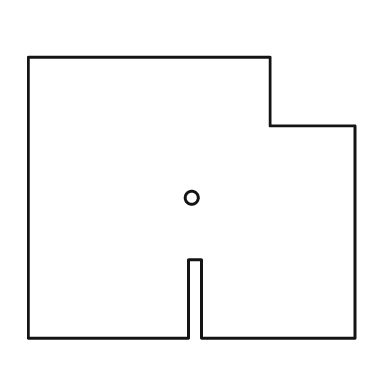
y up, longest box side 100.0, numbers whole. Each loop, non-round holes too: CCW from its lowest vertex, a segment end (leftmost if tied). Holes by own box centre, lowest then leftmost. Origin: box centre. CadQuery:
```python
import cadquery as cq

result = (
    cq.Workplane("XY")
    .moveTo(-50.0, -43.0)
    .lineTo(-1.0, -43.0)
    .lineTo(-1.0, -19.0)
    .lineTo(3.0, -19.0)
    .lineTo(3.0, -43.0)
    .lineTo(50.0, -43.0)
    .lineTo(50.0, 22.0)
    .lineTo(24.0, 22.0)
    .lineTo(24.0, 43.0)
    .lineTo(-50.0, 43.0)
    .close()
    .moveTo(0.0, 0.0)
    .circle(2.0)
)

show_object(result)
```